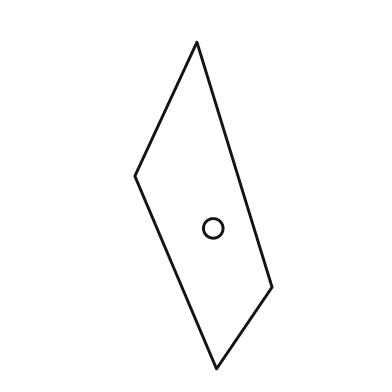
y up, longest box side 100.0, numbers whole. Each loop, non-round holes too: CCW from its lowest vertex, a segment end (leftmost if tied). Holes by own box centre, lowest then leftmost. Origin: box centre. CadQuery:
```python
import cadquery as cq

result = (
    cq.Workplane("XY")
    .moveTo(4.0, -50.0)
    .lineTo(21.0, -25.0)
    .lineTo(-2.0, 50.0)
    .lineTo(-21.0, 9.0)
    .close()
    .moveTo(3.0, -7.0)
    .circle(3.0)
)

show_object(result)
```